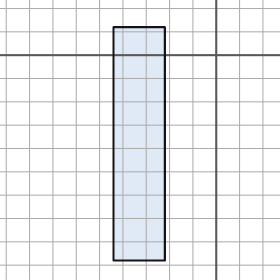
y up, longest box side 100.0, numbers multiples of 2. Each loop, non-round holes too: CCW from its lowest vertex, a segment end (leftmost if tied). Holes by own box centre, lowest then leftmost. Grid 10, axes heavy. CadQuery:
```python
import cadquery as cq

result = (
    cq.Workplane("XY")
    .moveTo(-44.0, -88.0)
    .lineTo(-22.0, -88.0)
    .lineTo(-22.0, 12.0)
    .lineTo(-44.0, 12.0)
    .close()
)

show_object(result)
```